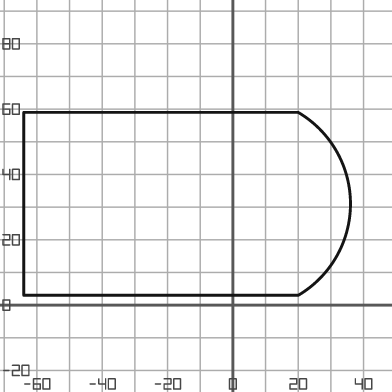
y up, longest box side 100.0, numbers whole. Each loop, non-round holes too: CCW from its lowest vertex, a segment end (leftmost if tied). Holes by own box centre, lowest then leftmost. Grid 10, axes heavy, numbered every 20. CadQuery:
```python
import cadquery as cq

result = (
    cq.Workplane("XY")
    .moveTo(-64.0, 3.0)
    .lineTo(20.0, 3.0)
    .threePointArc((36.0, 31.0), (20.0, 59.0))
    .lineTo(-64.0, 59.0)
    .close()
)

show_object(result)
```